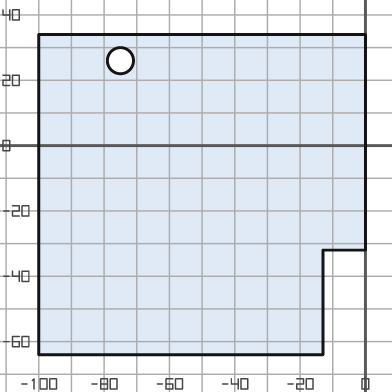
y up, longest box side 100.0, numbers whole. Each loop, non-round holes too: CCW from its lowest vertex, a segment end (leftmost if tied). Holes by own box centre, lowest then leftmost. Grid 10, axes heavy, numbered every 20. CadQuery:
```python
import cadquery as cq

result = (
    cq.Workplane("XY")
    .moveTo(-100.0, -64.0)
    .lineTo(-13.0, -64.0)
    .lineTo(-13.0, -32.0)
    .lineTo(0.0, -32.0)
    .lineTo(0.0, 34.0)
    .lineTo(-100.0, 34.0)
    .close()
    .moveTo(-75.0, 26.0)
    .circle(4.0)
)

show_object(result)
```